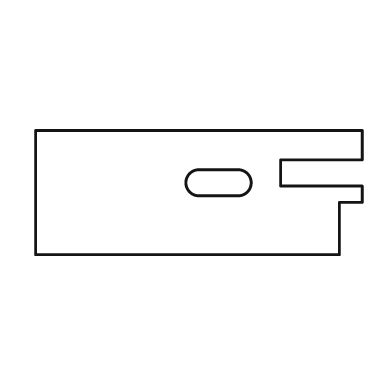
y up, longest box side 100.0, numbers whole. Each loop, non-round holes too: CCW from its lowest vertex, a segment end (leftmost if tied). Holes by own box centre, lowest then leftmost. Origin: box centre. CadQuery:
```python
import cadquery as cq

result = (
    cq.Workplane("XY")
    .moveTo(-50.0, -19.0)
    .lineTo(43.0, -19.0)
    .lineTo(43.0, -3.0)
    .lineTo(50.0, -3.0)
    .lineTo(50.0, 2.0)
    .lineTo(25.0, 2.0)
    .lineTo(25.0, 10.0)
    .lineTo(50.0, 10.0)
    .lineTo(50.0, 19.0)
    .lineTo(-50.0, 19.0)
    .close()
    .moveTo(0.0, -1.0)
    .lineTo(12.0, -1.0)
    .threePointArc((16.0, 3.0), (12.0, 7.0))
    .lineTo(0.0, 7.0)
    .threePointArc((-4.0, 3.0), (0.0, -1.0))
    .close()
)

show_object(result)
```